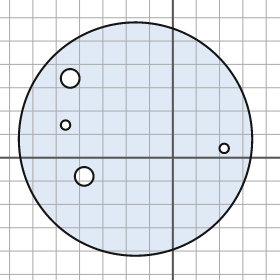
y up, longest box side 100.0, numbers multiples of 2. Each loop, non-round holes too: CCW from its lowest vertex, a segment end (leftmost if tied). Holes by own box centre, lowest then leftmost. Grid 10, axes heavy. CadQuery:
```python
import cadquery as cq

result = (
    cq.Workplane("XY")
    .moveTo(-16.0, 8.0)
    .circle(50.0)
    .moveTo(-38.0, -8.0)
    .circle(4.0)
    .moveTo(22.0, 4.0)
    .circle(2.0)
    .moveTo(-46.0, 14.0)
    .circle(2.0)
    .moveTo(-44.0, 34.0)
    .circle(4.0)
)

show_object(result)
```